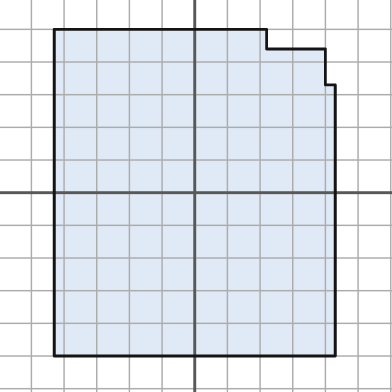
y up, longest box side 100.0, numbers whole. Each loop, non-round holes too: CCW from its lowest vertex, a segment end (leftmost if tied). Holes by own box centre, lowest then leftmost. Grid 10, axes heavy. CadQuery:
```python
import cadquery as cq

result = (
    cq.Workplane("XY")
    .moveTo(-43.0, -50.0)
    .lineTo(43.0, -50.0)
    .lineTo(43.0, 33.0)
    .lineTo(40.0, 33.0)
    .lineTo(40.0, 44.0)
    .lineTo(22.0, 44.0)
    .lineTo(22.0, 50.0)
    .lineTo(-43.0, 50.0)
    .close()
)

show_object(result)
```